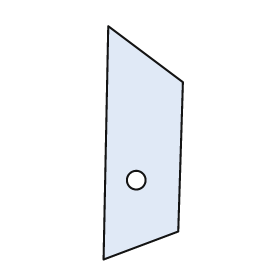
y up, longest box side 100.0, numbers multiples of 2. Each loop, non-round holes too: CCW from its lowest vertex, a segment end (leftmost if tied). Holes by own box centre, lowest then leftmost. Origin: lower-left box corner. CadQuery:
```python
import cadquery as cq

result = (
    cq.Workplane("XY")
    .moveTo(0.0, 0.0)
    .lineTo(32.0, 12.0)
    .lineTo(34.0, 76.0)
    .lineTo(2.0, 100.0)
    .close()
    .moveTo(14.0, 34.0)
    .circle(4.0)
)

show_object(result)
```